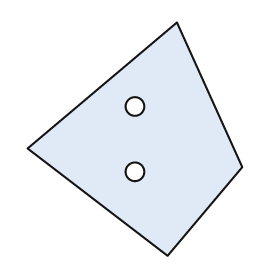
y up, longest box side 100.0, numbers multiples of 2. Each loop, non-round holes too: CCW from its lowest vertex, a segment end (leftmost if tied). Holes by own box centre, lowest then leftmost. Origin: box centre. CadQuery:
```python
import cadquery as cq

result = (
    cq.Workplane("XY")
    .moveTo(14.0, -50.0)
    .lineTo(46.0, -12.0)
    .lineTo(18.0, 50.0)
    .lineTo(-46.0, -4.0)
    .close()
    .moveTo(0.0, -14.0)
    .circle(4.0)
    .moveTo(0.0, 14.0)
    .circle(4.0)
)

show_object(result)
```